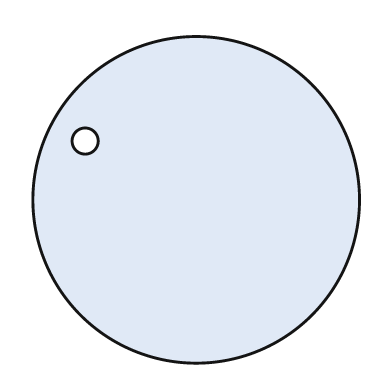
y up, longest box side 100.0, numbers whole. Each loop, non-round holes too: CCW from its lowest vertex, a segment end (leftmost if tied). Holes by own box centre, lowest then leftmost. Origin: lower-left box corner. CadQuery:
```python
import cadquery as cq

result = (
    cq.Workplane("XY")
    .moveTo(50.0, 50.0)
    .circle(50.0)
    .moveTo(16.0, 68.0)
    .circle(4.0)
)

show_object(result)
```